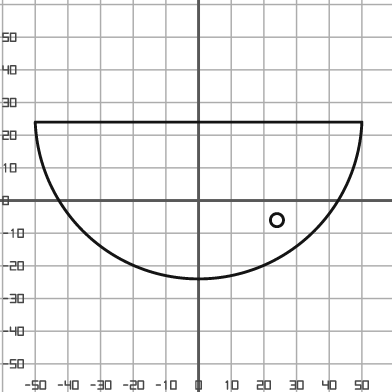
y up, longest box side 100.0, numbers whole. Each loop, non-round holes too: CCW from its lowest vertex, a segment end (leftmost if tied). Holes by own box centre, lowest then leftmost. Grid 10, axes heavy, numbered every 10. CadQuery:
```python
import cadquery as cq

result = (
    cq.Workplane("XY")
    .moveTo(-50.0, 24.0)
    .threePointArc((0.0, -24.0), (50.0, 24.0))
    .close()
    .moveTo(24.0, -6.0)
    .circle(2.0)
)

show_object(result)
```